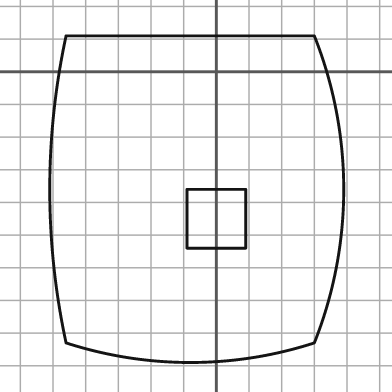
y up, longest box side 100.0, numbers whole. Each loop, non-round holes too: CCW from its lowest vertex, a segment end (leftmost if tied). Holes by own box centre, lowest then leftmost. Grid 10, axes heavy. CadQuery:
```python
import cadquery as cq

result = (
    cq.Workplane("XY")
    .moveTo(-46.0, -83.0)
    .threePointArc((-8.0, -89.0), (30.0, -83.0))
    .threePointArc((39.0, -36.0), (30.0, 11.0))
    .lineTo(-46.0, 11.0)
    .threePointArc((-51.0, -36.0), (-46.0, -83.0))
    .close()
    .moveTo(-9.0, -54.0)
    .lineTo(9.0, -54.0)
    .lineTo(9.0, -36.0)
    .lineTo(-9.0, -36.0)
    .close()
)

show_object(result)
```